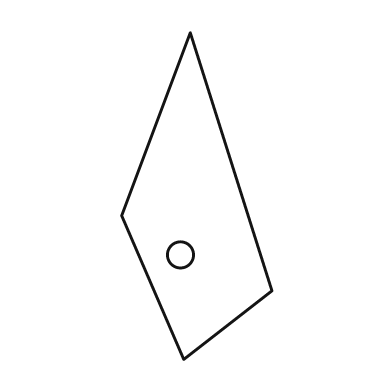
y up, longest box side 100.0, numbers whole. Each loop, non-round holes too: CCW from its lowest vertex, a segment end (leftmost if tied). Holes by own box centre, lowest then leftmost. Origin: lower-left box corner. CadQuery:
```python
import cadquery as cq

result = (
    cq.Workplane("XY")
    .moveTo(19.0, 0.0)
    .lineTo(46.0, 21.0)
    .lineTo(21.0, 100.0)
    .lineTo(0.0, 44.0)
    .close()
    .moveTo(18.0, 32.0)
    .circle(4.0)
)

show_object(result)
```